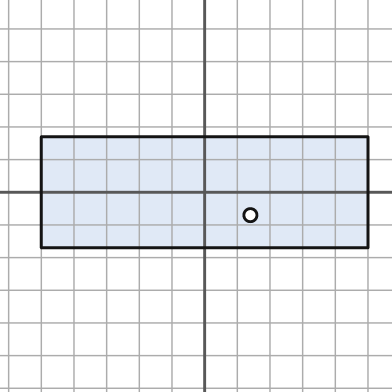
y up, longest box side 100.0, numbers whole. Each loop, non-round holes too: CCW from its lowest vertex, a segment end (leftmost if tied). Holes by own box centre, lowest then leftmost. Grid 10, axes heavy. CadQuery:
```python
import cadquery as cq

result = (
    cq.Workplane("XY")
    .moveTo(-50.0, -17.0)
    .lineTo(50.0, -17.0)
    .lineTo(50.0, 17.0)
    .lineTo(-50.0, 17.0)
    .close()
    .moveTo(14.0, -7.0)
    .circle(2.0)
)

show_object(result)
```